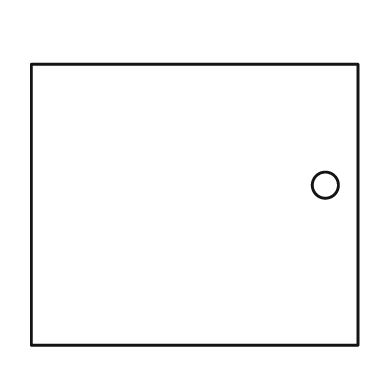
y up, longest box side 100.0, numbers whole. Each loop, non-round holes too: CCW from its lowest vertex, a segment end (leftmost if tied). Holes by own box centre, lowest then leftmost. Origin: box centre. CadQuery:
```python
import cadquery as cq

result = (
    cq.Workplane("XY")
    .moveTo(-50.0, -43.0)
    .lineTo(50.0, -43.0)
    .lineTo(50.0, 43.0)
    .lineTo(-50.0, 43.0)
    .close()
    .moveTo(40.0, 6.0)
    .circle(4.0)
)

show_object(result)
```